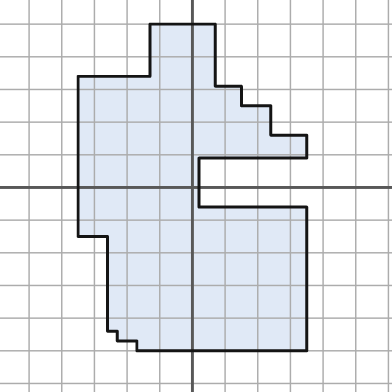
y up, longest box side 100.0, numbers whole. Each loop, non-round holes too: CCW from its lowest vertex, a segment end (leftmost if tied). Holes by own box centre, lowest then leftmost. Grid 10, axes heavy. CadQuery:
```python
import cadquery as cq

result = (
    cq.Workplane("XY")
    .moveTo(-17.0, -50.0)
    .lineTo(35.0, -50.0)
    .lineTo(35.0, -6.0)
    .lineTo(2.0, -6.0)
    .lineTo(2.0, 9.0)
    .lineTo(35.0, 9.0)
    .lineTo(35.0, 16.0)
    .lineTo(24.0, 16.0)
    .lineTo(24.0, 25.0)
    .lineTo(15.0, 25.0)
    .lineTo(15.0, 31.0)
    .lineTo(7.0, 31.0)
    .lineTo(7.0, 50.0)
    .lineTo(-13.0, 50.0)
    .lineTo(-13.0, 34.0)
    .lineTo(-35.0, 34.0)
    .lineTo(-35.0, -15.0)
    .lineTo(-26.0, -15.0)
    .lineTo(-26.0, -44.0)
    .lineTo(-23.0, -44.0)
    .lineTo(-23.0, -47.0)
    .lineTo(-17.0, -47.0)
    .close()
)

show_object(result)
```